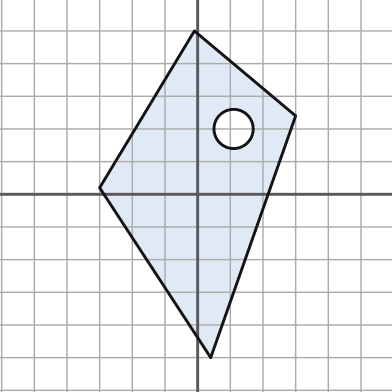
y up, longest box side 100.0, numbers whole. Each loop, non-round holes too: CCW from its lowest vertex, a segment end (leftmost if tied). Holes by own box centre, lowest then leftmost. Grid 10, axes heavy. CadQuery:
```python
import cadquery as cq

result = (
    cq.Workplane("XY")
    .moveTo(4.0, -50.0)
    .lineTo(30.0, 24.0)
    .lineTo(-1.0, 50.0)
    .lineTo(-30.0, 2.0)
    .close()
    .moveTo(11.0, 20.0)
    .circle(6.0)
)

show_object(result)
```